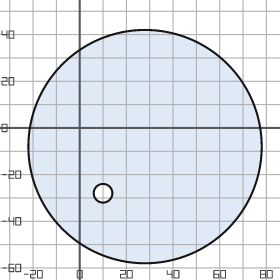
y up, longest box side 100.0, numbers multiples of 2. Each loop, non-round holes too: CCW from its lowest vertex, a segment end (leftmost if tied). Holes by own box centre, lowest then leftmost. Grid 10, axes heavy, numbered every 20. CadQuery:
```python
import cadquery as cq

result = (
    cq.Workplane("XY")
    .moveTo(28.0, -8.0)
    .circle(50.0)
    .moveTo(10.0, -28.0)
    .circle(4.0)
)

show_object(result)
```